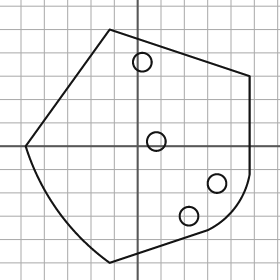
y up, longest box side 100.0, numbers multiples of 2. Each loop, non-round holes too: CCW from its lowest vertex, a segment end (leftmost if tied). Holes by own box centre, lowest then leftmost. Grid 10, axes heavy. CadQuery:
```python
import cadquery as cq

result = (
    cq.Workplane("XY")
    .moveTo(-12.0, -50.0)
    .lineTo(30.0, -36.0)
    .threePointArc((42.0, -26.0), (48.0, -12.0))
    .lineTo(48.0, 30.0)
    .lineTo(-12.0, 50.0)
    .lineTo(-48.0, 0.0)
    .threePointArc((-34.0, -28.0), (-12.0, -50.0))
    .close()
    .moveTo(22.0, -30.0)
    .circle(4.0)
    .moveTo(34.0, -16.0)
    .circle(4.0)
    .moveTo(8.0, 2.0)
    .circle(4.0)
    .moveTo(2.0, 36.0)
    .circle(4.0)
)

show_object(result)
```